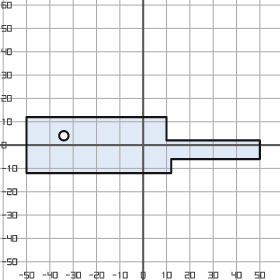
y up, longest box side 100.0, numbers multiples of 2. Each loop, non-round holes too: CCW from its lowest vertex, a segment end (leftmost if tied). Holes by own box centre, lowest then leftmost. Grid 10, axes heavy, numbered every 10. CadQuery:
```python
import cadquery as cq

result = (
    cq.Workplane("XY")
    .moveTo(-50.0, -12.0)
    .lineTo(12.0, -12.0)
    .lineTo(12.0, -6.0)
    .lineTo(50.0, -6.0)
    .lineTo(50.0, 2.0)
    .lineTo(10.0, 2.0)
    .lineTo(10.0, 12.0)
    .lineTo(-50.0, 12.0)
    .close()
    .moveTo(-34.0, 4.0)
    .circle(2.0)
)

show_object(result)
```